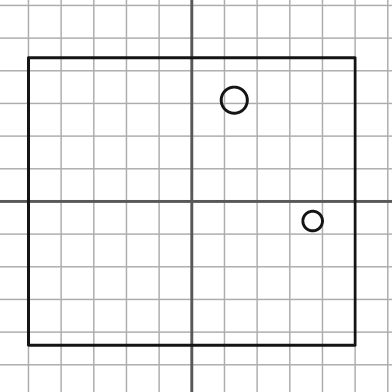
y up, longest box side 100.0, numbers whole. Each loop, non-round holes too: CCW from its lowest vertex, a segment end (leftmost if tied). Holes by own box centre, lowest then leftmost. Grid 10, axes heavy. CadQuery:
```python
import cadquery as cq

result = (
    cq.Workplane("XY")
    .moveTo(-50.0, -44.0)
    .lineTo(50.0, -44.0)
    .lineTo(50.0, 44.0)
    .lineTo(-50.0, 44.0)
    .close()
    .moveTo(37.0, -6.0)
    .circle(3.0)
    .moveTo(13.0, 31.0)
    .circle(4.0)
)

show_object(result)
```